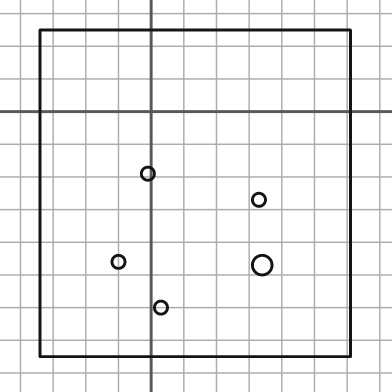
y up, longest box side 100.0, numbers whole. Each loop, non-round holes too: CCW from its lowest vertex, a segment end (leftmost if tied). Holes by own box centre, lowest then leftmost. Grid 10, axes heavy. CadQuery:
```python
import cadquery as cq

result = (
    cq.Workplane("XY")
    .moveTo(-34.0, -75.0)
    .lineTo(61.0, -75.0)
    .lineTo(61.0, 25.0)
    .lineTo(-34.0, 25.0)
    .close()
    .moveTo(3.0, -60.0)
    .circle(2.0)
    .moveTo(34.0, -47.0)
    .circle(3.0)
    .moveTo(-10.0, -46.0)
    .circle(2.0)
    .moveTo(33.0, -27.0)
    .circle(2.0)
    .moveTo(-1.0, -19.0)
    .circle(2.0)
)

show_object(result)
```